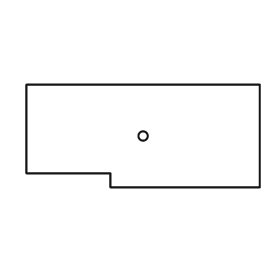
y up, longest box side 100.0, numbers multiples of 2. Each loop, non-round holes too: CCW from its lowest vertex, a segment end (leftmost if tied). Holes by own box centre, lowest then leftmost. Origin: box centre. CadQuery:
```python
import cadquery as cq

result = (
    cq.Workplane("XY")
    .moveTo(-14.0, -22.0)
    .lineTo(50.0, -22.0)
    .lineTo(50.0, 22.0)
    .lineTo(-50.0, 22.0)
    .lineTo(-50.0, -16.0)
    .lineTo(-14.0, -16.0)
    .close()
    .moveTo(0.0, 0.0)
    .circle(2.0)
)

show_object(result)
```